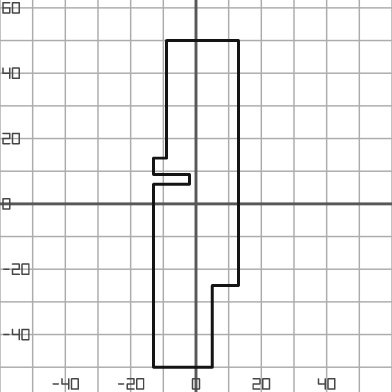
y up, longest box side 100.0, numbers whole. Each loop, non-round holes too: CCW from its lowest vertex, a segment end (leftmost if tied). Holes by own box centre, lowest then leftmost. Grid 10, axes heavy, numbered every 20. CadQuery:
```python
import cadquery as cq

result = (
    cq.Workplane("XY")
    .moveTo(-13.0, -50.0)
    .lineTo(5.0, -50.0)
    .lineTo(5.0, -25.0)
    .lineTo(13.0, -25.0)
    .lineTo(13.0, 50.0)
    .lineTo(-9.0, 50.0)
    .lineTo(-9.0, 14.0)
    .lineTo(-13.0, 14.0)
    .lineTo(-13.0, 9.0)
    .lineTo(-2.0, 9.0)
    .lineTo(-2.0, 6.0)
    .lineTo(-13.0, 6.0)
    .close()
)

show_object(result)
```